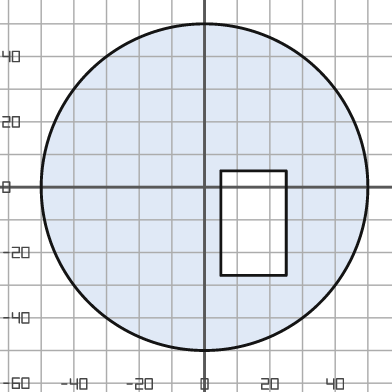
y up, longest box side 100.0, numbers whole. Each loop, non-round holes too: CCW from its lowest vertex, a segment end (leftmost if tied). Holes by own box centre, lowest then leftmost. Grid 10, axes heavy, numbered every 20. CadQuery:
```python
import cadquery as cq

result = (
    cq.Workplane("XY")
    .moveTo(0.0, 0.0)
    .circle(50.0)
    .moveTo(5.0, -27.0)
    .lineTo(25.0, -27.0)
    .lineTo(25.0, 5.0)
    .lineTo(5.0, 5.0)
    .close()
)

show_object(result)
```